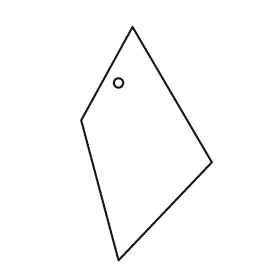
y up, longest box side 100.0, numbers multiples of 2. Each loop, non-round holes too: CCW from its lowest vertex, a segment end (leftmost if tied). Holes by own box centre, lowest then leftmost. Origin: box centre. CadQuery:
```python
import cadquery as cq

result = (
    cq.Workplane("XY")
    .moveTo(-12.0, -50.0)
    .lineTo(28.0, -8.0)
    .lineTo(-6.0, 50.0)
    .lineTo(-28.0, 10.0)
    .close()
    .moveTo(-12.0, 26.0)
    .circle(2.0)
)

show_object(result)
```